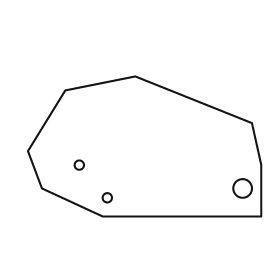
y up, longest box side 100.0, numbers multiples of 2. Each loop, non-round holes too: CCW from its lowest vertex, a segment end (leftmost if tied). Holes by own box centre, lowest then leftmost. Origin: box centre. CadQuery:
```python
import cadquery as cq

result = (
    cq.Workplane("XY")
    .moveTo(-18.0, -30.0)
    .lineTo(50.0, -30.0)
    .lineTo(50.0, -8.0)
    .lineTo(46.0, 10.0)
    .lineTo(-4.0, 30.0)
    .lineTo(-34.0, 24.0)
    .lineTo(-50.0, -2.0)
    .lineTo(-44.0, -18.0)
    .close()
    .moveTo(-16.0, -22.0)
    .circle(2.0)
    .moveTo(42.0, -18.0)
    .circle(4.0)
    .moveTo(-28.0, -8.0)
    .circle(2.0)
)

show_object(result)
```